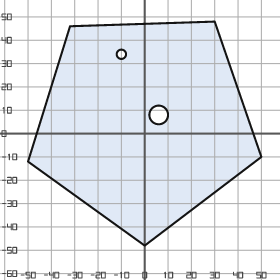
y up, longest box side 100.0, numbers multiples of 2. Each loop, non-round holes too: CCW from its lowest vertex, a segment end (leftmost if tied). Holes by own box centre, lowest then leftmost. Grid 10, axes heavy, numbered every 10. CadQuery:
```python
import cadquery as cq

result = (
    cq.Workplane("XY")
    .moveTo(0.0, -48.0)
    .lineTo(50.0, -10.0)
    .lineTo(30.0, 48.0)
    .lineTo(-32.0, 46.0)
    .lineTo(-50.0, -12.0)
    .close()
    .moveTo(6.0, 8.0)
    .circle(4.0)
    .moveTo(-10.0, 34.0)
    .circle(2.0)
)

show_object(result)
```